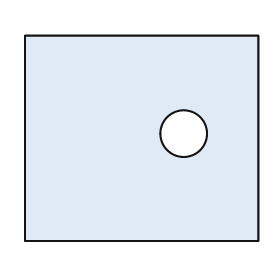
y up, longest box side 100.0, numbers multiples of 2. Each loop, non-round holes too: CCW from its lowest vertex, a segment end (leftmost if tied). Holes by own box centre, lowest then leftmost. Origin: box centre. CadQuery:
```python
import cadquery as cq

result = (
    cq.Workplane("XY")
    .moveTo(-50.0, -44.0)
    .lineTo(50.0, -44.0)
    .lineTo(50.0, 44.0)
    .lineTo(-50.0, 44.0)
    .close()
    .moveTo(18.0, 2.0)
    .circle(10.0)
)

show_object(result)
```